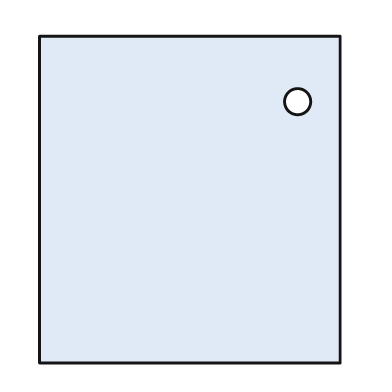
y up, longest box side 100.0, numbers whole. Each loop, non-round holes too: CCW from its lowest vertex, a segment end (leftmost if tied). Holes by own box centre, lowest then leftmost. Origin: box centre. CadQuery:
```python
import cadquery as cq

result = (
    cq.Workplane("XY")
    .moveTo(-46.0, -50.0)
    .lineTo(46.0, -50.0)
    .lineTo(46.0, 50.0)
    .lineTo(-46.0, 50.0)
    .close()
    .moveTo(33.0, 30.0)
    .circle(4.0)
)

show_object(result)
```